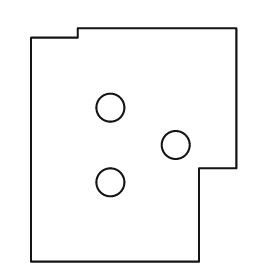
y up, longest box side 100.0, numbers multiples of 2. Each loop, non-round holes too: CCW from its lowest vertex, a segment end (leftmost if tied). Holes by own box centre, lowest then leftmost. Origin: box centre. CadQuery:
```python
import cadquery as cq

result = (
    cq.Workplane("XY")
    .moveTo(-44.0, -50.0)
    .lineTo(28.0, -50.0)
    .lineTo(28.0, -10.0)
    .lineTo(44.0, -10.0)
    .lineTo(44.0, 50.0)
    .lineTo(-24.0, 50.0)
    .lineTo(-24.0, 46.0)
    .lineTo(-44.0, 46.0)
    .close()
    .moveTo(-10.0, -16.0)
    .circle(6.0)
    .moveTo(18.0, 0.0)
    .circle(6.0)
    .moveTo(-10.0, 16.0)
    .circle(6.0)
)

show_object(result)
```